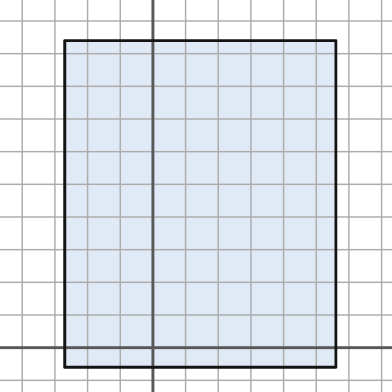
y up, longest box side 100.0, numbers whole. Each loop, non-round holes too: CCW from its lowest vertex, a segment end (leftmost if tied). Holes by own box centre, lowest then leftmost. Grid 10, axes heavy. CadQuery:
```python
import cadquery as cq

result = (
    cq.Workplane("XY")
    .moveTo(-27.0, -6.0)
    .lineTo(56.0, -6.0)
    .lineTo(56.0, 94.0)
    .lineTo(-27.0, 94.0)
    .close()
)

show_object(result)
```